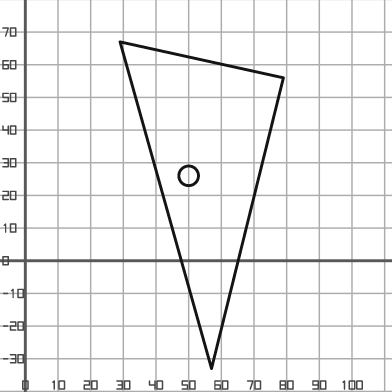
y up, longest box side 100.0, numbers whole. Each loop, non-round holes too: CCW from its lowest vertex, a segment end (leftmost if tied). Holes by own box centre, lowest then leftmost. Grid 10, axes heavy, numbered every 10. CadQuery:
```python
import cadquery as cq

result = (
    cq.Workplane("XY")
    .moveTo(57.0, -33.0)
    .lineTo(79.0, 56.0)
    .lineTo(29.0, 67.0)
    .close()
    .moveTo(50.0, 26.0)
    .circle(3.0)
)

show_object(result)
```